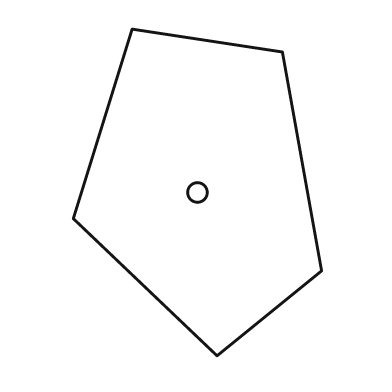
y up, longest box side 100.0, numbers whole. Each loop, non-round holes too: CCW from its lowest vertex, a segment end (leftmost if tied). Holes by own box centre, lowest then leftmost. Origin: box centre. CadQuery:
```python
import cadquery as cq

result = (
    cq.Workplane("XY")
    .moveTo(6.0, -50.0)
    .lineTo(38.0, -24.0)
    .lineTo(26.0, 43.0)
    .lineTo(-20.0, 50.0)
    .lineTo(-38.0, -8.0)
    .close()
    .moveTo(0.0, 0.0)
    .circle(3.0)
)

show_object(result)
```